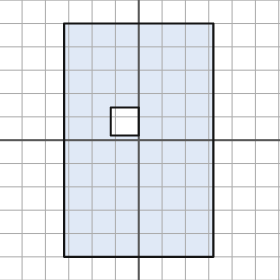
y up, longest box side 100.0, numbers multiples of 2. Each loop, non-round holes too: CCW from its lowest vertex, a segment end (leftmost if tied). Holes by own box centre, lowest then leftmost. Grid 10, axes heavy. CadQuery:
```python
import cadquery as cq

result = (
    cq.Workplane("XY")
    .moveTo(-32.0, -50.0)
    .lineTo(32.0, -50.0)
    .lineTo(32.0, 50.0)
    .lineTo(-32.0, 50.0)
    .close()
    .moveTo(-12.0, 2.0)
    .lineTo(0.0, 2.0)
    .lineTo(0.0, 14.0)
    .lineTo(-12.0, 14.0)
    .close()
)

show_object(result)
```